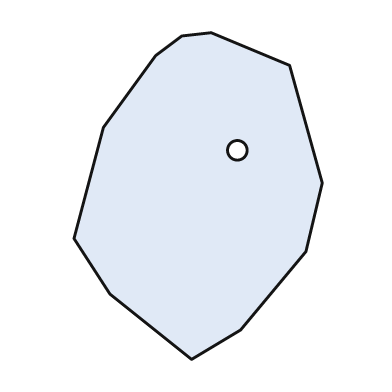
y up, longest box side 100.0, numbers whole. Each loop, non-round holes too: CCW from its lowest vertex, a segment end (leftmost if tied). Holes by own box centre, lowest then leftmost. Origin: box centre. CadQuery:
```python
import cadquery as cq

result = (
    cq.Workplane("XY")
    .moveTo(-2.0, -50.0)
    .lineTo(13.0, -41.0)
    .lineTo(33.0, -17.0)
    .lineTo(38.0, 4.0)
    .lineTo(28.0, 40.0)
    .lineTo(4.0, 50.0)
    .lineTo(-5.0, 49.0)
    .lineTo(-13.0, 43.0)
    .lineTo(-29.0, 21.0)
    .lineTo(-38.0, -13.0)
    .lineTo(-27.0, -30.0)
    .close()
    .moveTo(12.0, 14.0)
    .circle(3.0)
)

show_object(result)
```